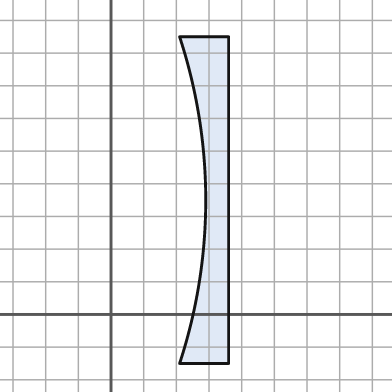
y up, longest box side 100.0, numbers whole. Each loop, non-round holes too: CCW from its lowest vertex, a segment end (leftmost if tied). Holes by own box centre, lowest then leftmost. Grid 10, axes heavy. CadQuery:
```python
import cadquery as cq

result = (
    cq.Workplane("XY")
    .moveTo(21.0, -15.0)
    .lineTo(36.0, -15.0)
    .lineTo(36.0, 85.0)
    .lineTo(21.0, 85.0)
    .threePointArc((29.0, 35.0), (21.0, -15.0))
    .close()
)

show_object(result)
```